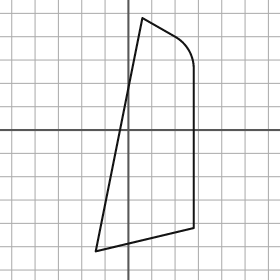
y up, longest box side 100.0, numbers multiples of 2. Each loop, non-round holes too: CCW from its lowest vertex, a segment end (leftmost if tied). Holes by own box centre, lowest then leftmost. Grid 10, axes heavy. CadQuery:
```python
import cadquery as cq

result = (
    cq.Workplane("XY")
    .moveTo(-14.0, -52.0)
    .lineTo(28.0, -42.0)
    .lineTo(28.0, 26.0)
    .threePointArc((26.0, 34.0), (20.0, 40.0))
    .lineTo(6.0, 48.0)
    .close()
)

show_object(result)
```